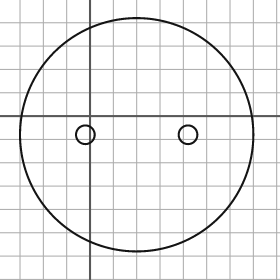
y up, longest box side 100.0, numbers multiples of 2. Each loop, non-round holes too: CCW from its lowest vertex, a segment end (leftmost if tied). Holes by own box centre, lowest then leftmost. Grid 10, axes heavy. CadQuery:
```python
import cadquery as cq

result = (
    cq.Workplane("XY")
    .moveTo(20.0, -8.0)
    .circle(50.0)
    .moveTo(-2.0, -8.0)
    .circle(4.0)
    .moveTo(42.0, -8.0)
    .circle(4.0)
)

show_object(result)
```